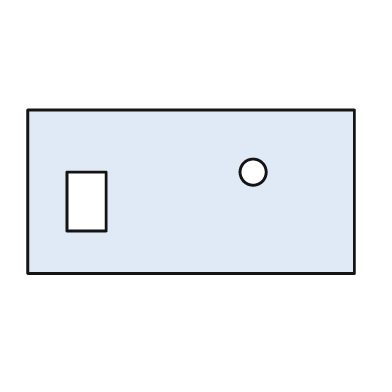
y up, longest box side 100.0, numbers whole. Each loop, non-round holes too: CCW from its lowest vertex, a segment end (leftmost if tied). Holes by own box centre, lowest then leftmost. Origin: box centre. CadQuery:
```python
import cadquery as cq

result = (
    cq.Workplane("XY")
    .moveTo(-50.0, -25.0)
    .lineTo(50.0, -25.0)
    .lineTo(50.0, 25.0)
    .lineTo(-50.0, 25.0)
    .close()
    .moveTo(-38.0, -12.0)
    .lineTo(-26.0, -12.0)
    .lineTo(-26.0, 6.0)
    .lineTo(-38.0, 6.0)
    .close()
    .moveTo(19.0, 6.0)
    .circle(4.0)
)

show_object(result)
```